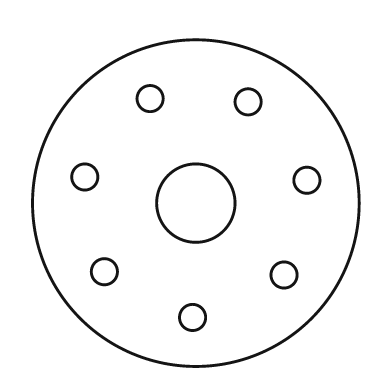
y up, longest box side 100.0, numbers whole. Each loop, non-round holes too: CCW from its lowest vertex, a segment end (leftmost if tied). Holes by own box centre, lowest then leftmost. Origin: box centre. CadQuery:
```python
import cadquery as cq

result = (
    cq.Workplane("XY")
    .moveTo(0.0, 0.0)
    .circle(50.0)
    .moveTo(-1.0, -35.0)
    .circle(4.0)
    .moveTo(27.0, -22.0)
    .circle(4.0)
    .moveTo(-28.0, -21.0)
    .circle(4.0)
    .moveTo(0.0, 0.0)
    .circle(12.0)
    .moveTo(34.0, 7.0)
    .circle(4.0)
    .moveTo(-34.0, 8.0)
    .circle(4.0)
    .moveTo(16.0, 31.0)
    .circle(4.0)
    .moveTo(-14.0, 32.0)
    .circle(4.0)
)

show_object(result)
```